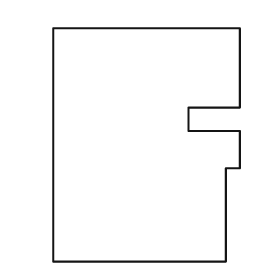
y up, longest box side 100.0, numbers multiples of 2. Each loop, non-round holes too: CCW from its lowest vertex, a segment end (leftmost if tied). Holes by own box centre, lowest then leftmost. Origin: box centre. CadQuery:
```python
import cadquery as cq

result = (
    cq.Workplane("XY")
    .moveTo(-40.0, -50.0)
    .lineTo(34.0, -50.0)
    .lineTo(34.0, -10.0)
    .lineTo(40.0, -10.0)
    .lineTo(40.0, 6.0)
    .lineTo(18.0, 6.0)
    .lineTo(18.0, 16.0)
    .lineTo(40.0, 16.0)
    .lineTo(40.0, 50.0)
    .lineTo(-40.0, 50.0)
    .close()
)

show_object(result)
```